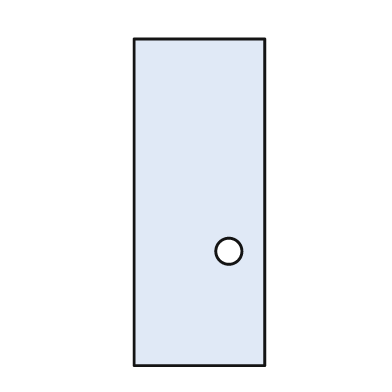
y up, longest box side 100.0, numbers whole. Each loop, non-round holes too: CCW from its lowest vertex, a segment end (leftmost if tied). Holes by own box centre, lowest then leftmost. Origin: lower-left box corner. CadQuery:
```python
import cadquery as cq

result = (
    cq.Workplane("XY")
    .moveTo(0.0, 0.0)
    .lineTo(40.0, 0.0)
    .lineTo(40.0, 100.0)
    .lineTo(0.0, 100.0)
    .close()
    .moveTo(29.0, 35.0)
    .circle(4.0)
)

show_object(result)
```